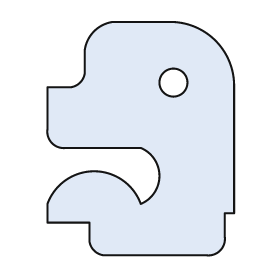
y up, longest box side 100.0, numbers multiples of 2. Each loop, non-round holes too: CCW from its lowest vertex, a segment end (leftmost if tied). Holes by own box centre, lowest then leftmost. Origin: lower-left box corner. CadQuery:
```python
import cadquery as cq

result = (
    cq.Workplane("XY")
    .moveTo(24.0, 0.0)
    .lineTo(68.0, 0.0)
    .threePointArc((74.0, 2.0), (76.0, 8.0))
    .lineTo(76.0, 18.0)
    .lineTo(80.0, 18.0)
    .lineTo(80.0, 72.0)
    .threePointArc((72.0, 92.0), (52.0, 100.0))
    .lineTo(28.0, 100.0)
    .threePointArc((20.0, 96.0), (16.0, 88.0))
    .lineTo(16.0, 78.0)
    .threePointArc((14.0, 74.0), (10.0, 72.0))
    .lineTo(0.0, 72.0)
    .lineTo(0.0, 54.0)
    .threePointArc((2.0, 48.0), (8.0, 46.0))
    .lineTo(40.0, 46.0)
    .threePointArc((48.0, 34.0), (40.0, 22.0))
    .threePointArc((20.0, 36.0), (0.0, 22.0))
    .lineTo(0.0, 14.0)
    .lineTo(18.0, 14.0)
    .lineTo(18.0, 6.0)
    .threePointArc((20.0, 2.0), (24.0, 0.0))
    .close()
    .moveTo(54.0, 74.0)
    .circle(6.0)
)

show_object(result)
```